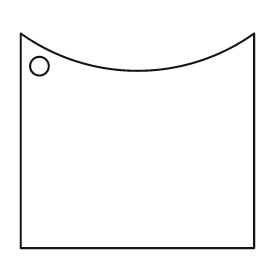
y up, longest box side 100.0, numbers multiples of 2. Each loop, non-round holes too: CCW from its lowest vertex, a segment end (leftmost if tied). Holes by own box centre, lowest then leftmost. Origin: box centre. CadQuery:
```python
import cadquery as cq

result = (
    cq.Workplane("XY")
    .moveTo(-50.0, -46.0)
    .lineTo(50.0, -46.0)
    .lineTo(50.0, 46.0)
    .threePointArc((0.0, 30.0), (-50.0, 46.0))
    .close()
    .moveTo(-42.0, 32.0)
    .circle(4.0)
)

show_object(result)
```